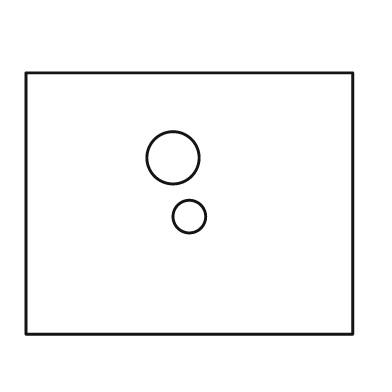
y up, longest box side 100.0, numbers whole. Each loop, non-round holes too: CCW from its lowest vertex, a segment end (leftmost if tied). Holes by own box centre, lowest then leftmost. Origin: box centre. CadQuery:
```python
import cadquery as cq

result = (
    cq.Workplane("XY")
    .moveTo(-50.0, -40.0)
    .lineTo(50.0, -40.0)
    .lineTo(50.0, 40.0)
    .lineTo(-50.0, 40.0)
    .close()
    .moveTo(0.0, -4.0)
    .circle(5.0)
    .moveTo(-5.0, 14.0)
    .circle(8.0)
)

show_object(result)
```